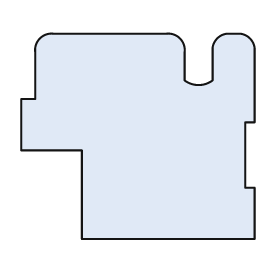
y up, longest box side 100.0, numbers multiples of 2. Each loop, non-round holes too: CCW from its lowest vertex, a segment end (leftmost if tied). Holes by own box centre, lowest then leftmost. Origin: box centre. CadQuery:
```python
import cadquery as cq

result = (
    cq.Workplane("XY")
    .moveTo(-24.0, -44.0)
    .lineTo(50.0, -44.0)
    .lineTo(50.0, -22.0)
    .lineTo(46.0, -22.0)
    .lineTo(46.0, 6.0)
    .lineTo(50.0, 6.0)
    .lineTo(50.0, 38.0)
    .threePointArc((48.0, 42.0), (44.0, 44.0))
    .lineTo(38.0, 44.0)
    .threePointArc((34.0, 42.0), (32.0, 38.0))
    .lineTo(32.0, 24.0)
    .threePointArc((26.0, 22.0), (20.0, 24.0))
    .lineTo(20.0, 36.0)
    .threePointArc((18.0, 42.0), (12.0, 44.0))
    .lineTo(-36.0, 44.0)
    .threePointArc((-42.0, 42.0), (-44.0, 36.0))
    .lineTo(-44.0, 16.0)
    .lineTo(-50.0, 16.0)
    .lineTo(-50.0, -6.0)
    .lineTo(-24.0, -6.0)
    .close()
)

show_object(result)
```